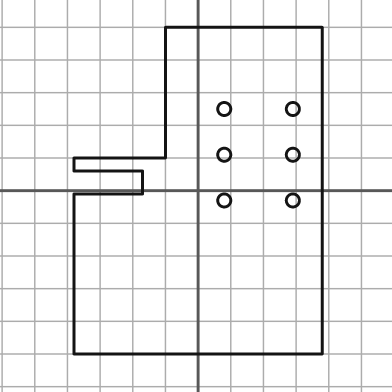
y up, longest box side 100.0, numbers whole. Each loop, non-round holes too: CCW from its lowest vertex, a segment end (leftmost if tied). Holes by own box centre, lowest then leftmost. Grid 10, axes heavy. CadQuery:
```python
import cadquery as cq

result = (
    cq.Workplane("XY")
    .moveTo(-38.0, -50.0)
    .lineTo(38.0, -50.0)
    .lineTo(38.0, 50.0)
    .lineTo(-10.0, 50.0)
    .lineTo(-10.0, 10.0)
    .lineTo(-38.0, 10.0)
    .lineTo(-38.0, 6.0)
    .lineTo(-17.0, 6.0)
    .lineTo(-17.0, -1.0)
    .lineTo(-38.0, -1.0)
    .close()
    .moveTo(8.0, -3.0)
    .circle(2.0)
    .moveTo(29.0, -3.0)
    .circle(2.0)
    .moveTo(8.0, 11.0)
    .circle(2.0)
    .moveTo(29.0, 11.0)
    .circle(2.0)
    .moveTo(8.0, 25.0)
    .circle(2.0)
    .moveTo(29.0, 25.0)
    .circle(2.0)
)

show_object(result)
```